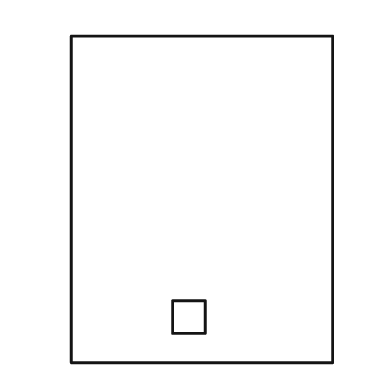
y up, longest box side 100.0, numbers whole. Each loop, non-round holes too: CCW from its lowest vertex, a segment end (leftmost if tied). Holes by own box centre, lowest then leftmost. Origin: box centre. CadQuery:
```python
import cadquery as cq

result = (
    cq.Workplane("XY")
    .moveTo(-40.0, -50.0)
    .lineTo(40.0, -50.0)
    .lineTo(40.0, 50.0)
    .lineTo(-40.0, 50.0)
    .close()
    .moveTo(-9.0, -41.0)
    .lineTo(1.0, -41.0)
    .lineTo(1.0, -31.0)
    .lineTo(-9.0, -31.0)
    .close()
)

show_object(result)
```